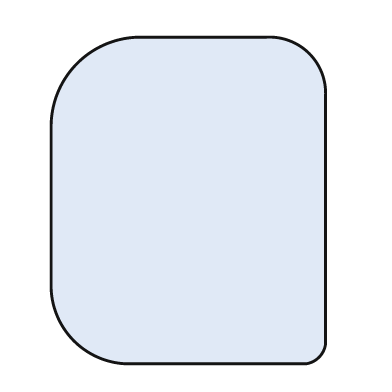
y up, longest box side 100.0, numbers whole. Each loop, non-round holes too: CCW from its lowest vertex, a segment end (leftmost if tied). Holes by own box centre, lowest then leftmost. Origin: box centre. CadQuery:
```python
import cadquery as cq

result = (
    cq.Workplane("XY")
    .moveTo(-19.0, -50.0)
    .lineTo(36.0, -50.0)
    .threePointArc((40.0, -48.0), (42.0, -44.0))
    .lineTo(42.0, 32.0)
    .threePointArc((37.0, 45.0), (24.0, 50.0))
    .lineTo(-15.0, 50.0)
    .threePointArc((-34.0, 42.0), (-42.0, 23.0))
    .lineTo(-42.0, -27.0)
    .threePointArc((-35.0, -43.0), (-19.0, -50.0))
    .close()
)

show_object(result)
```